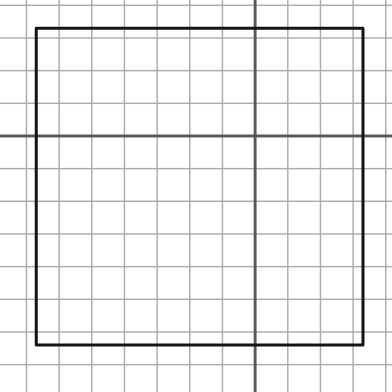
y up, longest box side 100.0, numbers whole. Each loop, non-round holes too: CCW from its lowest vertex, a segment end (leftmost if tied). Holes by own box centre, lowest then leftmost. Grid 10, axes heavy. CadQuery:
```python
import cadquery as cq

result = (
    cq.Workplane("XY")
    .moveTo(-67.0, -64.0)
    .lineTo(33.0, -64.0)
    .lineTo(33.0, 33.0)
    .lineTo(-67.0, 33.0)
    .close()
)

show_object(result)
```